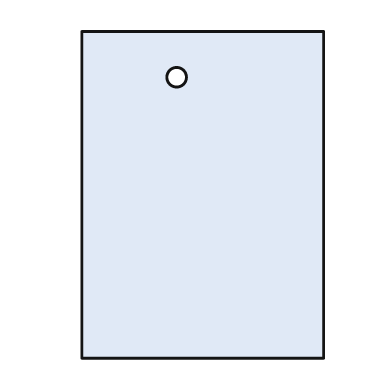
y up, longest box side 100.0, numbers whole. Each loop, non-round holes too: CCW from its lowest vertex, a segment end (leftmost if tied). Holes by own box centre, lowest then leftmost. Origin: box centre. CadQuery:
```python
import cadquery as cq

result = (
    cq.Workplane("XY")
    .moveTo(-37.0, -50.0)
    .lineTo(37.0, -50.0)
    .lineTo(37.0, 50.0)
    .lineTo(-37.0, 50.0)
    .close()
    .moveTo(-8.0, 36.0)
    .circle(3.0)
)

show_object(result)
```